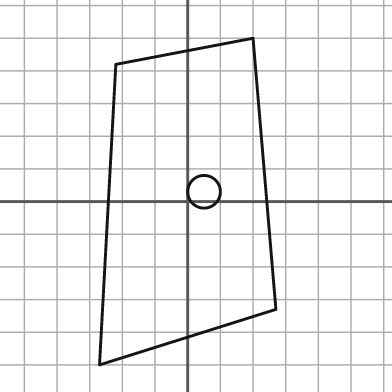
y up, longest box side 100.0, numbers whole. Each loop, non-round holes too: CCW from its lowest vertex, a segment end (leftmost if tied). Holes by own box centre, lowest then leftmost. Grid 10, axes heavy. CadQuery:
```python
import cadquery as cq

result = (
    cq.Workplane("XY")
    .moveTo(-27.0, -50.0)
    .lineTo(27.0, -33.0)
    .lineTo(20.0, 50.0)
    .lineTo(-22.0, 42.0)
    .close()
    .moveTo(5.0, 3.0)
    .circle(5.0)
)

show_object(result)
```